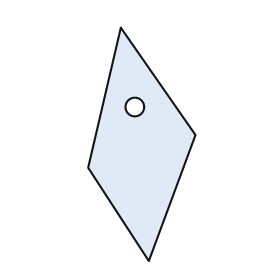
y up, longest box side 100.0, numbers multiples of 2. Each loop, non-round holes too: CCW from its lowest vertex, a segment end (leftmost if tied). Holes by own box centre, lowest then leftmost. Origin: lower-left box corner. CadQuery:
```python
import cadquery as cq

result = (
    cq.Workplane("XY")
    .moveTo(26.0, 0.0)
    .lineTo(46.0, 54.0)
    .lineTo(14.0, 100.0)
    .lineTo(0.0, 40.0)
    .close()
    .moveTo(20.0, 66.0)
    .circle(4.0)
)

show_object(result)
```